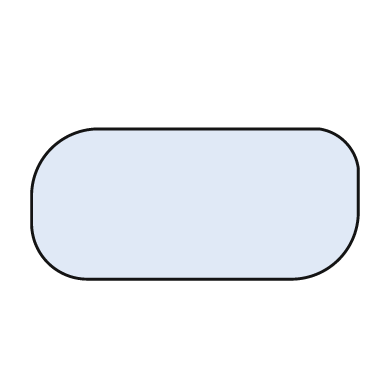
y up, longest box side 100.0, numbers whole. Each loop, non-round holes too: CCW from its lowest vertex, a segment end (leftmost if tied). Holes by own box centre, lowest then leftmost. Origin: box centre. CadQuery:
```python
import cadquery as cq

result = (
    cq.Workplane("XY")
    .moveTo(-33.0, -23.0)
    .lineTo(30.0, -23.0)
    .threePointArc((44.0, -17.0), (50.0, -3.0))
    .lineTo(50.0, 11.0)
    .threePointArc((46.0, 19.0), (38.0, 23.0))
    .lineTo(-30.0, 23.0)
    .threePointArc((-44.0, 17.0), (-50.0, 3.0))
    .lineTo(-50.0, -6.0)
    .threePointArc((-45.0, -18.0), (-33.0, -23.0))
    .close()
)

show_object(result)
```